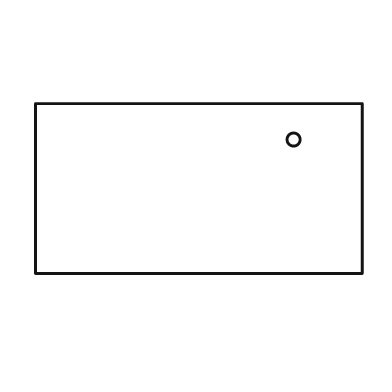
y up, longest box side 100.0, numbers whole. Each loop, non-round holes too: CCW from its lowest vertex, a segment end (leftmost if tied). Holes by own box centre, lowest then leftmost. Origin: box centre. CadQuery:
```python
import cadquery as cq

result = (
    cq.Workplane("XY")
    .moveTo(-50.0, -26.0)
    .lineTo(50.0, -26.0)
    .lineTo(50.0, 26.0)
    .lineTo(-50.0, 26.0)
    .close()
    .moveTo(29.0, 15.0)
    .circle(2.0)
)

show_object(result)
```